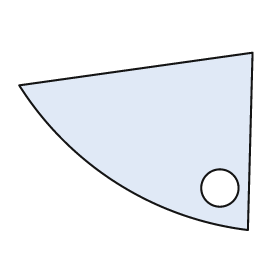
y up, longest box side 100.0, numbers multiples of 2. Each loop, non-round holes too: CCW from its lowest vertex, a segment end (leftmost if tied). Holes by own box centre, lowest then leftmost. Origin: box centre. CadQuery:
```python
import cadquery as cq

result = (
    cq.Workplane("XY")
    .moveTo(48.0, -38.0)
    .lineTo(50.0, 38.0)
    .lineTo(-50.0, 24.0)
    .threePointArc((-8.0, -18.0), (48.0, -38.0))
    .close()
    .moveTo(36.0, -20.0)
    .circle(8.0)
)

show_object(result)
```